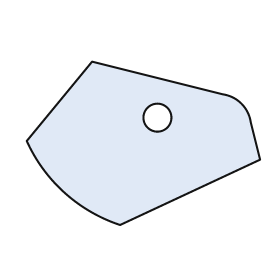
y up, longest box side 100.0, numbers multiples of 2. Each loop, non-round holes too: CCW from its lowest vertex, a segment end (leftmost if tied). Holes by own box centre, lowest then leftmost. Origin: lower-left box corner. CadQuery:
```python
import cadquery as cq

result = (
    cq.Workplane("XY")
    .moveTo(40.0, 0.0)
    .lineTo(100.0, 28.0)
    .lineTo(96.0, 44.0)
    .threePointArc((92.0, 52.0), (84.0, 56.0))
    .lineTo(28.0, 70.0)
    .lineTo(0.0, 36.0)
    .threePointArc((16.0, 14.0), (40.0, 0.0))
    .close()
    .moveTo(56.0, 46.0)
    .circle(6.0)
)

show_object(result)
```